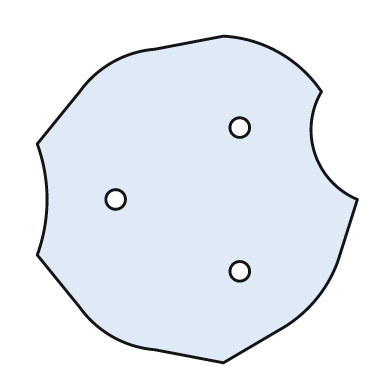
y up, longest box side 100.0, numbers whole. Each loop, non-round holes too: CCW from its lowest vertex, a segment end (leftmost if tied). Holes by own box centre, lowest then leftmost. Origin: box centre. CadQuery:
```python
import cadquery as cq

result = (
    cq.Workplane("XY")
    .moveTo(8.0, -50.0)
    .lineTo(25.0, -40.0)
    .threePointArc((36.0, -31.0), (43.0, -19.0))
    .lineTo(49.0, 0.0)
    .threePointArc((36.0, 14.0), (38.0, 33.0))
    .threePointArc((25.0, 45.0), (8.0, 50.0))
    .lineTo(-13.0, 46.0)
    .threePointArc((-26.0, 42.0), (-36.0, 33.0))
    .lineTo(-49.0, 17.0)
    .threePointArc((-46.0, 0.0), (-49.0, -17.0))
    .lineTo(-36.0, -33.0)
    .threePointArc((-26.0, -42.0), (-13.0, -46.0))
    .close()
    .moveTo(13.0, -22.0)
    .circle(3.0)
    .moveTo(-25.0, 0.0)
    .circle(3.0)
    .moveTo(13.0, 22.0)
    .circle(3.0)
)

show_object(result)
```